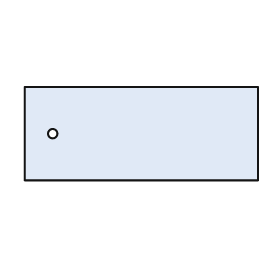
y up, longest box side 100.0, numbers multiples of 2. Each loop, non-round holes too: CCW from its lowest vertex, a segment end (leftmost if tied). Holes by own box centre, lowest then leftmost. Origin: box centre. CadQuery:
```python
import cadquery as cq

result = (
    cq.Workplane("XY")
    .moveTo(-50.0, -20.0)
    .lineTo(50.0, -20.0)
    .lineTo(50.0, 20.0)
    .lineTo(-50.0, 20.0)
    .close()
    .moveTo(-38.0, 0.0)
    .circle(2.0)
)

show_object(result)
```